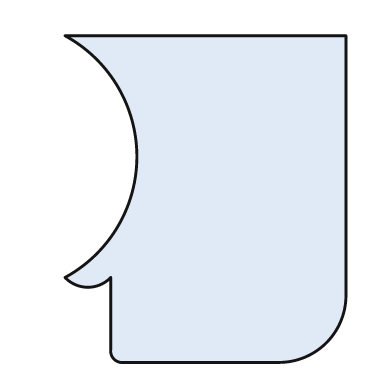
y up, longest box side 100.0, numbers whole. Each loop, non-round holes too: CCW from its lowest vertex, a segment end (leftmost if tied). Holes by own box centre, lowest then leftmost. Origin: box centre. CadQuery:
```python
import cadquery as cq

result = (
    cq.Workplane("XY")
    .moveTo(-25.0, -50.0)
    .lineTo(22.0, -50.0)
    .threePointArc((37.0, -44.0), (43.0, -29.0))
    .lineTo(43.0, 50.0)
    .lineTo(-43.0, 50.0)
    .threePointArc((-21.0, 13.0), (-43.0, -24.0))
    .threePointArc((-36.0, -27.0), (-29.0, -24.0))
    .lineTo(-29.0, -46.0)
    .threePointArc((-28.0, -49.0), (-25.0, -50.0))
    .close()
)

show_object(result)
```